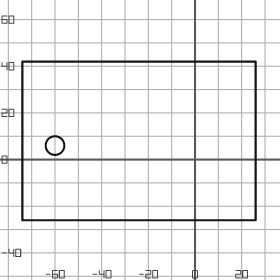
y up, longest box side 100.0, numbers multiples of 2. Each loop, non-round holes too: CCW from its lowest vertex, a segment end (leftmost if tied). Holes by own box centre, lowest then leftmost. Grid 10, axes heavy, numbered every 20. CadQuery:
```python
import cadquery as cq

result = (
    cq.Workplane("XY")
    .moveTo(-74.0, -26.0)
    .lineTo(26.0, -26.0)
    .lineTo(26.0, 42.0)
    .lineTo(-74.0, 42.0)
    .close()
    .moveTo(-60.0, 6.0)
    .circle(4.0)
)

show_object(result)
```